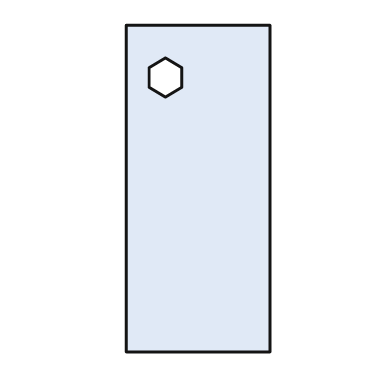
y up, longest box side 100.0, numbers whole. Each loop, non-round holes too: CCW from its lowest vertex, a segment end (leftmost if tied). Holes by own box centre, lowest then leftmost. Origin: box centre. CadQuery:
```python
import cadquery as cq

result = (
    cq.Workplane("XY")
    .moveTo(-22.0, -50.0)
    .lineTo(22.0, -50.0)
    .lineTo(22.0, 50.0)
    .lineTo(-22.0, 50.0)
    .close()
    .moveTo(-10.0, 28.0)
    .lineTo(-5.0, 31.0)
    .lineTo(-5.0, 37.0)
    .lineTo(-10.0, 40.0)
    .lineTo(-15.0, 37.0)
    .lineTo(-15.0, 31.0)
    .close()
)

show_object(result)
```